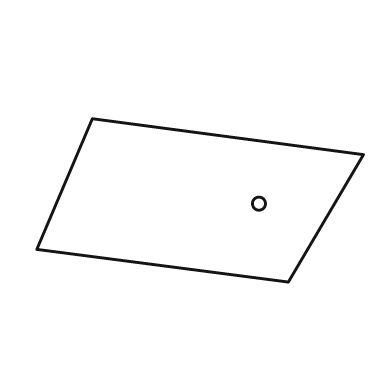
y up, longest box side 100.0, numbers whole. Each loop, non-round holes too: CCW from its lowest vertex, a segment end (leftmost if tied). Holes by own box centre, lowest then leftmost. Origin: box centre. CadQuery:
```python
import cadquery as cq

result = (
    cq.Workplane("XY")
    .moveTo(27.0, -25.0)
    .lineTo(50.0, 14.0)
    .lineTo(-33.0, 25.0)
    .lineTo(-50.0, -15.0)
    .close()
    .moveTo(18.0, -1.0)
    .circle(2.0)
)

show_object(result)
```